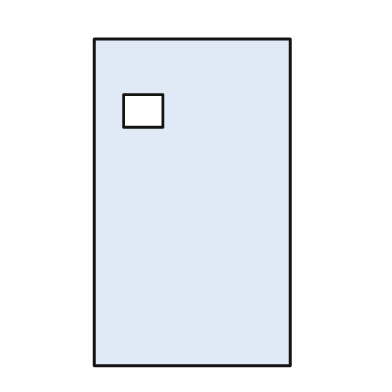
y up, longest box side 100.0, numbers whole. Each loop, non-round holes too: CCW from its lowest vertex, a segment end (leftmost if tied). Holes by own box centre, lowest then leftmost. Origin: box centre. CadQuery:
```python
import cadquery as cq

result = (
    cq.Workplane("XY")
    .moveTo(-30.0, -50.0)
    .lineTo(30.0, -50.0)
    .lineTo(30.0, 50.0)
    .lineTo(-30.0, 50.0)
    .close()
    .moveTo(-21.0, 23.0)
    .lineTo(-9.0, 23.0)
    .lineTo(-9.0, 33.0)
    .lineTo(-21.0, 33.0)
    .close()
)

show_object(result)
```